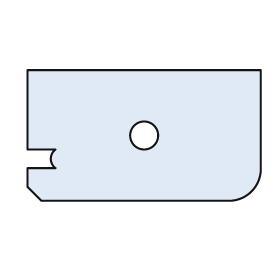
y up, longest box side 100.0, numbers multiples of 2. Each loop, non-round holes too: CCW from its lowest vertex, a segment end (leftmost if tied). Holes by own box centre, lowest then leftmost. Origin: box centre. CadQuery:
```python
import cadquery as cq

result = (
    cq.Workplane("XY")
    .moveTo(-44.0, -28.0)
    .lineTo(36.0, -28.0)
    .threePointArc((46.0, -24.0), (50.0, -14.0))
    .lineTo(50.0, 28.0)
    .lineTo(-50.0, 28.0)
    .lineTo(-50.0, -6.0)
    .lineTo(-38.0, -6.0)
    .threePointArc((-40.0, -10.0), (-38.0, -14.0))
    .lineTo(-50.0, -14.0)
    .lineTo(-50.0, -22.0)
    .close()
    .moveTo(0.0, 0.0)
    .circle(6.0)
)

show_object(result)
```